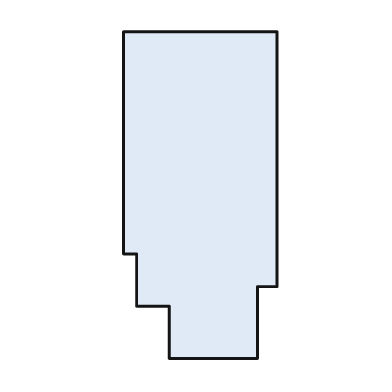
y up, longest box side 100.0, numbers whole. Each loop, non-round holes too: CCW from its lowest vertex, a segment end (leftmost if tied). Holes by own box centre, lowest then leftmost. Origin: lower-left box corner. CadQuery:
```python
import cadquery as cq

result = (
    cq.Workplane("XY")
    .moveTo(14.0, 0.0)
    .lineTo(41.0, 0.0)
    .lineTo(41.0, 22.0)
    .lineTo(47.0, 22.0)
    .lineTo(47.0, 100.0)
    .lineTo(0.0, 100.0)
    .lineTo(0.0, 32.0)
    .lineTo(4.0, 32.0)
    .lineTo(4.0, 16.0)
    .lineTo(14.0, 16.0)
    .close()
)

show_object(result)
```